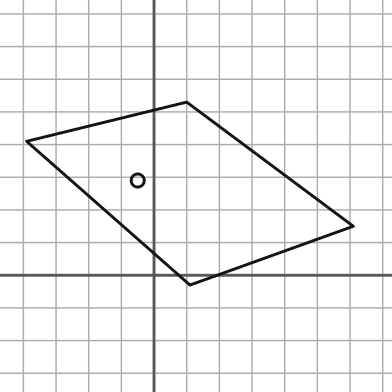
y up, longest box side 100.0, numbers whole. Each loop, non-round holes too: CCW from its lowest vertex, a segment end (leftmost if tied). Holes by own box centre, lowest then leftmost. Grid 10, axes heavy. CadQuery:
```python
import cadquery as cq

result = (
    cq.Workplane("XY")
    .moveTo(11.0, -3.0)
    .lineTo(61.0, 15.0)
    .lineTo(10.0, 53.0)
    .lineTo(-39.0, 41.0)
    .close()
    .moveTo(-5.0, 29.0)
    .circle(2.0)
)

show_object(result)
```